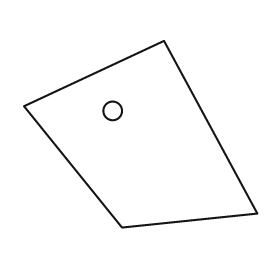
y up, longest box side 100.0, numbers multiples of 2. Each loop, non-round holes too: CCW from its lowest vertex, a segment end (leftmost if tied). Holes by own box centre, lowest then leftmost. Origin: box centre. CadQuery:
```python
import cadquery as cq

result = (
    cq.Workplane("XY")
    .moveTo(-8.0, -40.0)
    .lineTo(50.0, -34.0)
    .lineTo(10.0, 40.0)
    .lineTo(-50.0, 12.0)
    .close()
    .moveTo(-12.0, 10.0)
    .circle(4.0)
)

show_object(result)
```